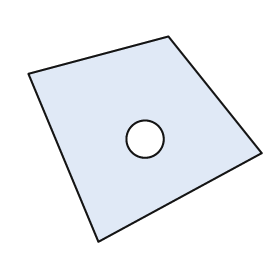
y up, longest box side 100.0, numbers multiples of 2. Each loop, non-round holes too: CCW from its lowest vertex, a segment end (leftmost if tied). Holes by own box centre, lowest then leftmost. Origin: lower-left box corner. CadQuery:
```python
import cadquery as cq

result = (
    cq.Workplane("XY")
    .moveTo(30.0, 0.0)
    .lineTo(100.0, 38.0)
    .lineTo(60.0, 88.0)
    .lineTo(0.0, 72.0)
    .close()
    .moveTo(50.0, 44.0)
    .circle(8.0)
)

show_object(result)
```